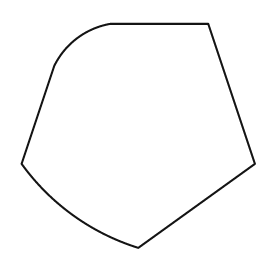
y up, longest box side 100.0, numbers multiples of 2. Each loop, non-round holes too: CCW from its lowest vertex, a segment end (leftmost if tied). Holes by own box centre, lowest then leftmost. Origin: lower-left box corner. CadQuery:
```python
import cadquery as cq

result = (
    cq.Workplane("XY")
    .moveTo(50.0, 0.0)
    .lineTo(100.0, 36.0)
    .lineTo(80.0, 96.0)
    .lineTo(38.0, 96.0)
    .threePointArc((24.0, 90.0), (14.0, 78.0))
    .lineTo(0.0, 36.0)
    .threePointArc((22.0, 14.0), (50.0, 0.0))
    .close()
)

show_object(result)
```